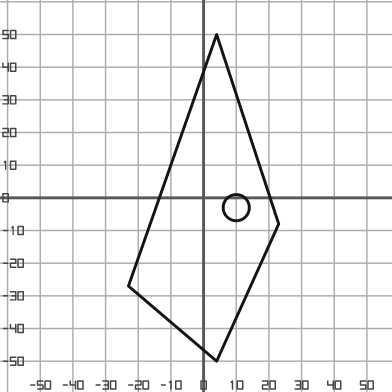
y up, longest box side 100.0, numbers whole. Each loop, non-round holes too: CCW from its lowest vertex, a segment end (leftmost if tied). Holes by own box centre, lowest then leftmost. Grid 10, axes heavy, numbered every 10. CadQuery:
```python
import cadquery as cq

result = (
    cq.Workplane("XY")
    .moveTo(4.0, -50.0)
    .lineTo(23.0, -8.0)
    .lineTo(4.0, 50.0)
    .lineTo(-23.0, -27.0)
    .close()
    .moveTo(10.0, -3.0)
    .circle(4.0)
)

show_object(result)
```